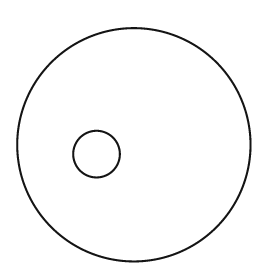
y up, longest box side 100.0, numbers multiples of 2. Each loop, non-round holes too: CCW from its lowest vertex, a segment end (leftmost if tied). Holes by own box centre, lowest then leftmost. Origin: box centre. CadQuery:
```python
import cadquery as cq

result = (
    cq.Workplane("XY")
    .moveTo(0.0, 0.0)
    .circle(50.0)
    .moveTo(-16.0, -4.0)
    .circle(10.0)
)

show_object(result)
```